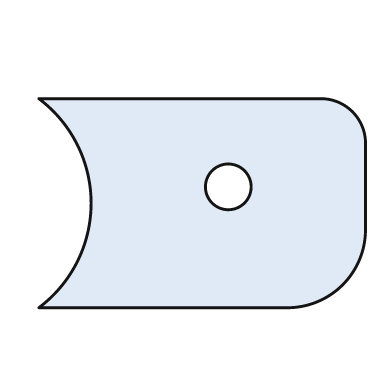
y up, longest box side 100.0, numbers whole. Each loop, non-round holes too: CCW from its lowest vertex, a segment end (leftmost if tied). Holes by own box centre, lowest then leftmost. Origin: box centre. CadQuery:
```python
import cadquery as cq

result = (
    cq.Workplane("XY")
    .moveTo(-50.0, -32.0)
    .lineTo(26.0, -32.0)
    .threePointArc((43.0, -25.0), (50.0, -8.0))
    .lineTo(50.0, 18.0)
    .threePointArc((46.0, 28.0), (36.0, 32.0))
    .lineTo(-50.0, 32.0)
    .threePointArc((-34.0, 0.0), (-50.0, -32.0))
    .close()
    .moveTo(8.0, 5.0)
    .circle(7.0)
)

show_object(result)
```